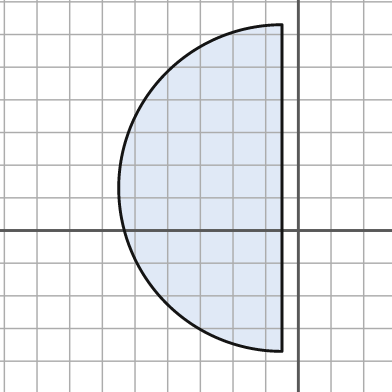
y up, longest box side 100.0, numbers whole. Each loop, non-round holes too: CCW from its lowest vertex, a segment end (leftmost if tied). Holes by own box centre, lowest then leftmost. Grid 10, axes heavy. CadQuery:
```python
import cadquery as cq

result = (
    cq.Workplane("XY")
    .moveTo(-5.0, -37.0)
    .lineTo(-5.0, 63.0)
    .threePointArc((-55.0, 13.0), (-5.0, -37.0))
    .close()
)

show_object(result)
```